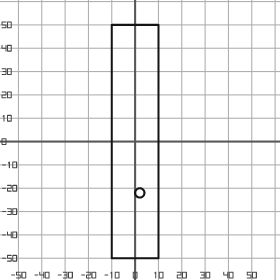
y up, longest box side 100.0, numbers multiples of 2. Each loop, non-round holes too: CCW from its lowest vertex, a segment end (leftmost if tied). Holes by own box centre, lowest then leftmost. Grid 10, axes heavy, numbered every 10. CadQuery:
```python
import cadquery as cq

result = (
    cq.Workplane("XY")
    .moveTo(-10.0, -50.0)
    .lineTo(10.0, -50.0)
    .lineTo(10.0, 50.0)
    .lineTo(-10.0, 50.0)
    .close()
    .moveTo(2.0, -22.0)
    .circle(2.0)
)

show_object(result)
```